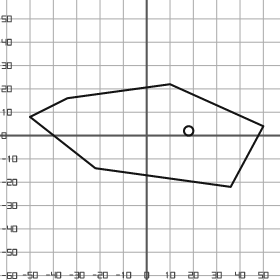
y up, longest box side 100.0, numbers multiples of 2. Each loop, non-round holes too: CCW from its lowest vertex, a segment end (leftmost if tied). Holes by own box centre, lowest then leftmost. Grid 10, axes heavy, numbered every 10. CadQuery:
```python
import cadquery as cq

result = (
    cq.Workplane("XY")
    .moveTo(36.0, -22.0)
    .lineTo(50.0, 4.0)
    .lineTo(10.0, 22.0)
    .lineTo(-34.0, 16.0)
    .lineTo(-50.0, 8.0)
    .lineTo(-22.0, -14.0)
    .close()
    .moveTo(18.0, 2.0)
    .circle(2.0)
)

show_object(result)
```